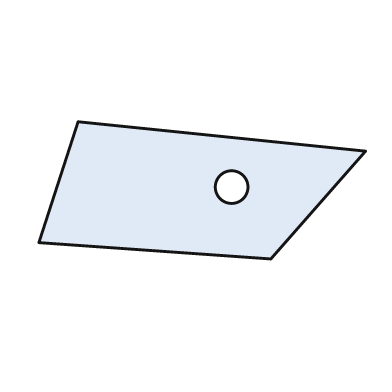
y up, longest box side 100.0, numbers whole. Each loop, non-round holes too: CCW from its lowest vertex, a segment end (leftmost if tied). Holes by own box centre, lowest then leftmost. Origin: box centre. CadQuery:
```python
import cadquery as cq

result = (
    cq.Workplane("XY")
    .moveTo(21.0, -21.0)
    .lineTo(50.0, 12.0)
    .lineTo(-38.0, 21.0)
    .lineTo(-50.0, -16.0)
    .close()
    .moveTo(9.0, 1.0)
    .circle(5.0)
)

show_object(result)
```